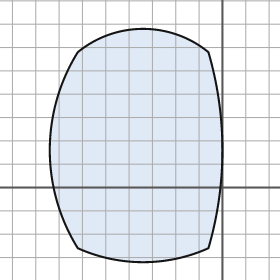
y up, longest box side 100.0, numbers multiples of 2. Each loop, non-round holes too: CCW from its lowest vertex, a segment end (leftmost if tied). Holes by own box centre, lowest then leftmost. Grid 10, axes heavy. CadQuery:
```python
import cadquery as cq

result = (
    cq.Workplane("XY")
    .moveTo(-62.0, -26.0)
    .threePointArc((-34.0, -32.0), (-6.0, -26.0))
    .threePointArc((0.0, 16.0), (-6.0, 58.0))
    .threePointArc((-34.0, 68.0), (-62.0, 58.0))
    .threePointArc((-74.0, 16.0), (-62.0, -26.0))
    .close()
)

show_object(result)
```